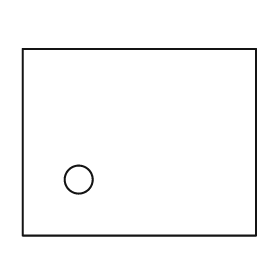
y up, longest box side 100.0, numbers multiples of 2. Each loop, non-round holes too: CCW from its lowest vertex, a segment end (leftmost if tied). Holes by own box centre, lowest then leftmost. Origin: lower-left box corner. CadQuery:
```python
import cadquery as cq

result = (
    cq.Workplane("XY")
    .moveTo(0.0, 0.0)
    .lineTo(100.0, 0.0)
    .lineTo(100.0, 80.0)
    .lineTo(0.0, 80.0)
    .close()
    .moveTo(24.0, 24.0)
    .circle(6.0)
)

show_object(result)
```